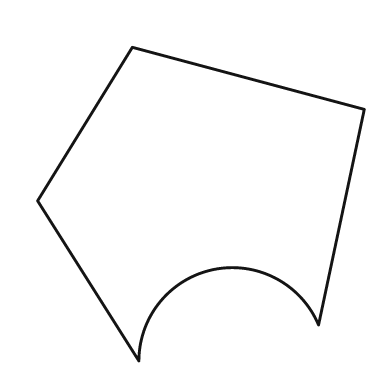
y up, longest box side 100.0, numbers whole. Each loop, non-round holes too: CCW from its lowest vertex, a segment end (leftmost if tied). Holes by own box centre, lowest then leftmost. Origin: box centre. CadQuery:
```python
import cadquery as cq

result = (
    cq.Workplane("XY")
    .moveTo(-19.0, -48.0)
    .threePointArc((4.0, -20.0), (36.0, -37.0))
    .lineTo(50.0, 29.0)
    .lineTo(-21.0, 48.0)
    .lineTo(-50.0, 1.0)
    .close()
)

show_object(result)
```